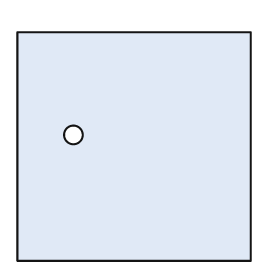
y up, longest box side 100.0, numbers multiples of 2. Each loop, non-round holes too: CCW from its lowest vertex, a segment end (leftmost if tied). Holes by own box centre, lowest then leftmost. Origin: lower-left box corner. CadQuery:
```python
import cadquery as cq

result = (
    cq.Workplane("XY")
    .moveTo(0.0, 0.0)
    .lineTo(100.0, 0.0)
    .lineTo(100.0, 98.0)
    .lineTo(0.0, 98.0)
    .close()
    .moveTo(24.0, 54.0)
    .circle(4.0)
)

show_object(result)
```